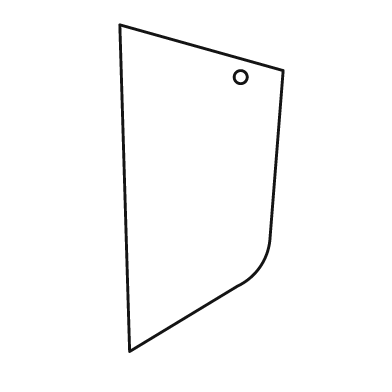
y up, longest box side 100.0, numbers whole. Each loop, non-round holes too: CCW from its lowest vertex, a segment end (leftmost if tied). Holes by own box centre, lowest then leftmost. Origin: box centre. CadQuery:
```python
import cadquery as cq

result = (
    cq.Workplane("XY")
    .moveTo(-22.0, -50.0)
    .lineTo(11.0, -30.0)
    .threePointArc((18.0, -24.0), (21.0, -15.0))
    .lineTo(25.0, 36.0)
    .lineTo(-25.0, 50.0)
    .close()
    .moveTo(12.0, 34.0)
    .circle(2.0)
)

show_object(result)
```